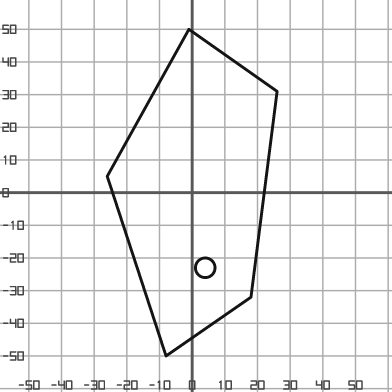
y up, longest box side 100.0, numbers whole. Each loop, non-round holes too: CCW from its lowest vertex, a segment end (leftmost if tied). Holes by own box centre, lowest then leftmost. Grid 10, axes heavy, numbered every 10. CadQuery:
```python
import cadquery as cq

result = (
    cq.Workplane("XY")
    .moveTo(-8.0, -50.0)
    .lineTo(18.0, -32.0)
    .lineTo(26.0, 31.0)
    .lineTo(-1.0, 50.0)
    .lineTo(-26.0, 5.0)
    .close()
    .moveTo(4.0, -23.0)
    .circle(3.0)
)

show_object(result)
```